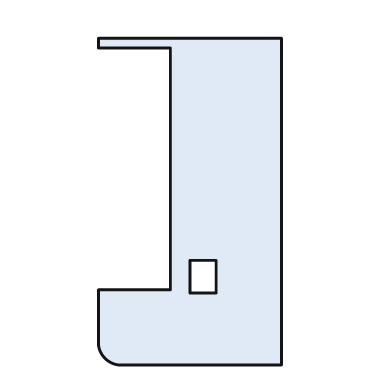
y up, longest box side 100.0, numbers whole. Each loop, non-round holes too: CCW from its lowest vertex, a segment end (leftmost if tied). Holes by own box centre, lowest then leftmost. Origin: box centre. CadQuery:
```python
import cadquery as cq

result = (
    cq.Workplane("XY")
    .moveTo(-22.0, -50.0)
    .lineTo(28.0, -50.0)
    .lineTo(28.0, 50.0)
    .lineTo(-28.0, 50.0)
    .lineTo(-28.0, 47.0)
    .lineTo(-6.0, 47.0)
    .lineTo(-6.0, -27.0)
    .lineTo(-28.0, -27.0)
    .lineTo(-28.0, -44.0)
    .threePointArc((-26.0, -48.0), (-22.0, -50.0))
    .close()
    .moveTo(0.0, -28.0)
    .lineTo(8.0, -28.0)
    .lineTo(8.0, -18.0)
    .lineTo(0.0, -18.0)
    .close()
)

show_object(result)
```